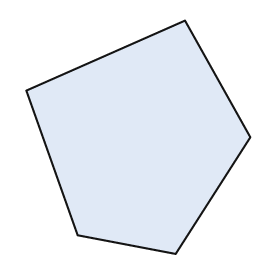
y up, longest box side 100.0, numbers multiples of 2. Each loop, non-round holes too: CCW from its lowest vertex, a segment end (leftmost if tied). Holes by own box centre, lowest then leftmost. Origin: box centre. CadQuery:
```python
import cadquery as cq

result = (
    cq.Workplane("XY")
    .moveTo(16.0, -50.0)
    .lineTo(48.0, 0.0)
    .lineTo(20.0, 50.0)
    .lineTo(-48.0, 20.0)
    .lineTo(-26.0, -42.0)
    .close()
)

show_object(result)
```